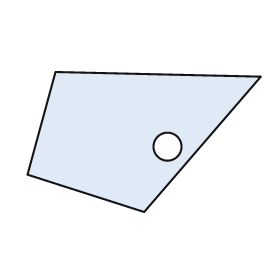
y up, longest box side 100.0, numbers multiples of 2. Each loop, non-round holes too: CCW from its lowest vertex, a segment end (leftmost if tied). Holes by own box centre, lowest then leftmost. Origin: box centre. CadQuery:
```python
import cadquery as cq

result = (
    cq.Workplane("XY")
    .moveTo(0.0, -30.0)
    .lineTo(50.0, 28.0)
    .lineTo(-38.0, 30.0)
    .lineTo(-50.0, -14.0)
    .close()
    .moveTo(10.0, -2.0)
    .circle(6.0)
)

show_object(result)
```